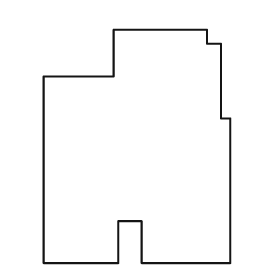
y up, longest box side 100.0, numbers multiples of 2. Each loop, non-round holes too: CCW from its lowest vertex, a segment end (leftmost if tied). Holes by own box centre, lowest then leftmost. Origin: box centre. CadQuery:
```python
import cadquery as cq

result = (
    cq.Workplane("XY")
    .moveTo(-40.0, -50.0)
    .lineTo(-8.0, -50.0)
    .lineTo(-8.0, -32.0)
    .lineTo(2.0, -32.0)
    .lineTo(2.0, -50.0)
    .lineTo(40.0, -50.0)
    .lineTo(40.0, 12.0)
    .lineTo(36.0, 12.0)
    .lineTo(36.0, 44.0)
    .lineTo(30.0, 44.0)
    .lineTo(30.0, 50.0)
    .lineTo(-10.0, 50.0)
    .lineTo(-10.0, 30.0)
    .lineTo(-40.0, 30.0)
    .close()
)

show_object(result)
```